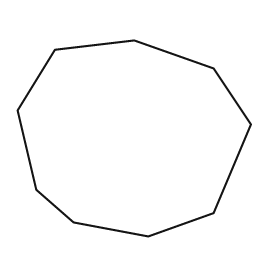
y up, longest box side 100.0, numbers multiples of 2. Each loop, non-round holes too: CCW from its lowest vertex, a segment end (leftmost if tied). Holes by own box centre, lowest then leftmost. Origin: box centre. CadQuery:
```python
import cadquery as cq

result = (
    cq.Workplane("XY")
    .moveTo(6.0, -42.0)
    .lineTo(34.0, -32.0)
    .lineTo(50.0, 6.0)
    .lineTo(34.0, 30.0)
    .lineTo(0.0, 42.0)
    .lineTo(-34.0, 38.0)
    .lineTo(-50.0, 12.0)
    .lineTo(-42.0, -22.0)
    .lineTo(-26.0, -36.0)
    .close()
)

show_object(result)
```